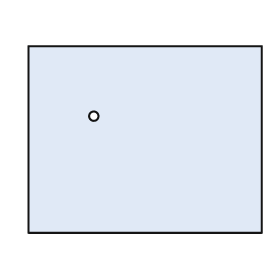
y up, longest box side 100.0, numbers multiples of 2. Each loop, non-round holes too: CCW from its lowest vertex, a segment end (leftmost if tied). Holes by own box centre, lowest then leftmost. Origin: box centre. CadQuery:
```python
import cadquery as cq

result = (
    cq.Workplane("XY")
    .moveTo(-50.0, -40.0)
    .lineTo(50.0, -40.0)
    .lineTo(50.0, 40.0)
    .lineTo(-50.0, 40.0)
    .close()
    .moveTo(-22.0, 10.0)
    .circle(2.0)
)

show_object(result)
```